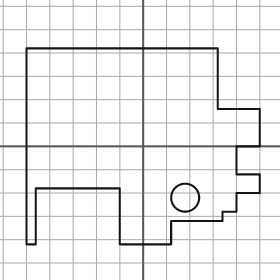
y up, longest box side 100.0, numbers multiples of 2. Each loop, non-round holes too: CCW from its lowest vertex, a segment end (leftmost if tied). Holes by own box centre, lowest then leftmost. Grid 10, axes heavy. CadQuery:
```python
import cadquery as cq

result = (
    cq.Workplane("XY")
    .moveTo(-50.0, -42.0)
    .lineTo(-46.0, -42.0)
    .lineTo(-46.0, -18.0)
    .lineTo(-10.0, -18.0)
    .lineTo(-10.0, -42.0)
    .lineTo(12.0, -42.0)
    .lineTo(12.0, -32.0)
    .lineTo(34.0, -32.0)
    .lineTo(34.0, -28.0)
    .lineTo(40.0, -28.0)
    .lineTo(40.0, -20.0)
    .lineTo(50.0, -20.0)
    .lineTo(50.0, -12.0)
    .lineTo(40.0, -12.0)
    .lineTo(40.0, 0.0)
    .lineTo(50.0, 0.0)
    .lineTo(50.0, 16.0)
    .lineTo(32.0, 16.0)
    .lineTo(32.0, 42.0)
    .lineTo(-50.0, 42.0)
    .close()
    .moveTo(18.0, -22.0)
    .circle(6.0)
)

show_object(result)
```